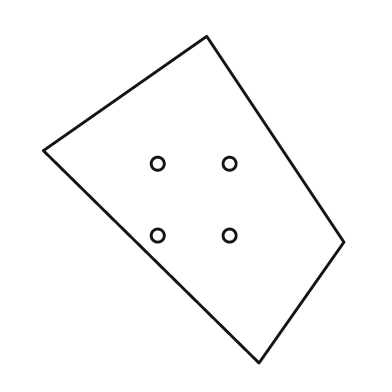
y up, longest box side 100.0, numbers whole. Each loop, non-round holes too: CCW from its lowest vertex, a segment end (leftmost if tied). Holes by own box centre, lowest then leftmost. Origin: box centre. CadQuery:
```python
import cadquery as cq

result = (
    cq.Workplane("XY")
    .moveTo(20.0, -50.0)
    .lineTo(46.0, -13.0)
    .lineTo(4.0, 50.0)
    .lineTo(-46.0, 15.0)
    .close()
    .moveTo(-11.0, -11.0)
    .circle(2.0)
    .moveTo(11.0, -11.0)
    .circle(2.0)
    .moveTo(-11.0, 11.0)
    .circle(2.0)
    .moveTo(11.0, 11.0)
    .circle(2.0)
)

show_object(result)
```